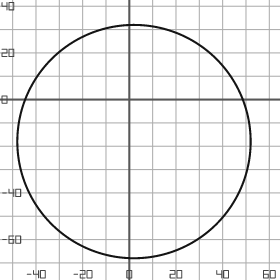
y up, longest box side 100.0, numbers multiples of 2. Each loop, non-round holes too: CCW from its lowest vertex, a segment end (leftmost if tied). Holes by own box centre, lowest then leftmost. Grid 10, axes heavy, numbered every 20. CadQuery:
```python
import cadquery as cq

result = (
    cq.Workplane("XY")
    .moveTo(2.0, -18.0)
    .circle(50.0)
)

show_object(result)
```